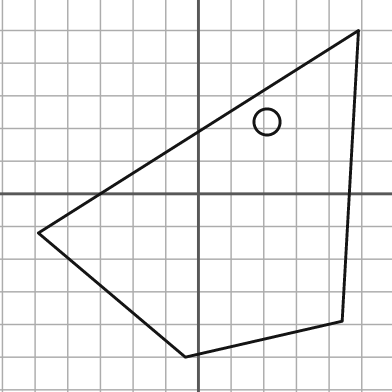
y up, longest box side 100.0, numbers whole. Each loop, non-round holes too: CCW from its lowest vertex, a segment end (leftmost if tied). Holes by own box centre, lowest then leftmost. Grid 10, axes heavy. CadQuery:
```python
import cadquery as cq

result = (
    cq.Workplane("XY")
    .moveTo(-4.0, -50.0)
    .lineTo(44.0, -39.0)
    .lineTo(49.0, 50.0)
    .lineTo(-49.0, -12.0)
    .close()
    .moveTo(21.0, 22.0)
    .circle(4.0)
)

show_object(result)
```